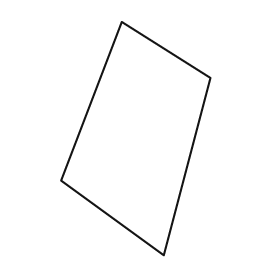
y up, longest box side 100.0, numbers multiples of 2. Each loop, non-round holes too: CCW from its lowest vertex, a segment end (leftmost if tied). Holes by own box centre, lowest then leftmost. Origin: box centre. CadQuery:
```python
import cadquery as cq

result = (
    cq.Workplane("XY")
    .moveTo(12.0, -50.0)
    .lineTo(32.0, 26.0)
    .lineTo(-6.0, 50.0)
    .lineTo(-32.0, -18.0)
    .close()
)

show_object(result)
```